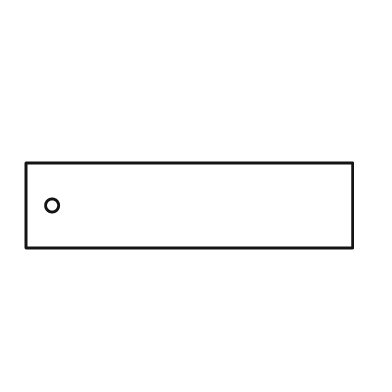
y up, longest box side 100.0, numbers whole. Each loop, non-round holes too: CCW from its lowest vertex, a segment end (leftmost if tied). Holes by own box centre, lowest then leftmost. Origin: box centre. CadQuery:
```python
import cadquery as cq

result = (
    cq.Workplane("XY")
    .moveTo(-50.0, -13.0)
    .lineTo(50.0, -13.0)
    .lineTo(50.0, 13.0)
    .lineTo(-50.0, 13.0)
    .close()
    .moveTo(-42.0, 0.0)
    .circle(2.0)
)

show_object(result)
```